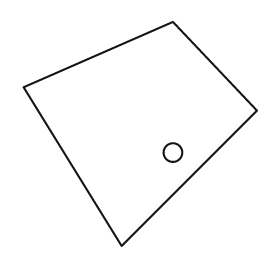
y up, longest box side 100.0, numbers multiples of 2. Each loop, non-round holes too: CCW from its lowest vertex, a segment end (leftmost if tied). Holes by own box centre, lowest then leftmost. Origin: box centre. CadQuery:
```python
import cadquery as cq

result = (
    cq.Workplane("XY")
    .moveTo(-8.0, -48.0)
    .lineTo(50.0, 10.0)
    .lineTo(14.0, 48.0)
    .lineTo(-50.0, 20.0)
    .close()
    .moveTo(14.0, -8.0)
    .circle(4.0)
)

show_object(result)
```